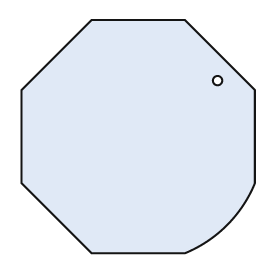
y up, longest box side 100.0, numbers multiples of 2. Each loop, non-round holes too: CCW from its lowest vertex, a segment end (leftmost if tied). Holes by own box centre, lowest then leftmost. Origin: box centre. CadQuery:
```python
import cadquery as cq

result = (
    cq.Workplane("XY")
    .moveTo(-20.0, -50.0)
    .lineTo(20.0, -50.0)
    .threePointArc((38.0, -38.0), (50.0, -20.0))
    .lineTo(50.0, 20.0)
    .lineTo(20.0, 50.0)
    .lineTo(-20.0, 50.0)
    .lineTo(-50.0, 20.0)
    .lineTo(-50.0, -20.0)
    .close()
    .moveTo(34.0, 24.0)
    .circle(2.0)
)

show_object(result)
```